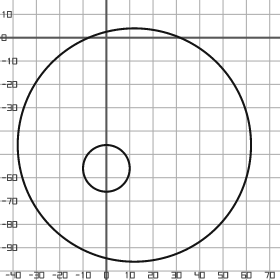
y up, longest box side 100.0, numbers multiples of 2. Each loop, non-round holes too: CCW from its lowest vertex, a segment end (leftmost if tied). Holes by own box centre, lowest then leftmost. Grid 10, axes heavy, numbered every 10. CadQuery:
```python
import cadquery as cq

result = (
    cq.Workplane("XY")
    .moveTo(12.0, -46.0)
    .circle(50.0)
    .moveTo(0.0, -56.0)
    .circle(10.0)
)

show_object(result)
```